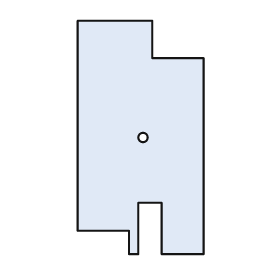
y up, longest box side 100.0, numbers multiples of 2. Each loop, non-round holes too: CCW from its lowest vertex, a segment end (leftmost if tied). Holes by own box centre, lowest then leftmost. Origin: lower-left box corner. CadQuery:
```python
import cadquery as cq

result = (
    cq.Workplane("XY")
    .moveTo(22.0, 0.0)
    .lineTo(26.0, 0.0)
    .lineTo(26.0, 22.0)
    .lineTo(36.0, 22.0)
    .lineTo(36.0, 0.0)
    .lineTo(54.0, 0.0)
    .lineTo(54.0, 84.0)
    .lineTo(32.0, 84.0)
    .lineTo(32.0, 100.0)
    .lineTo(0.0, 100.0)
    .lineTo(0.0, 10.0)
    .lineTo(22.0, 10.0)
    .close()
    .moveTo(28.0, 50.0)
    .circle(2.0)
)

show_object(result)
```